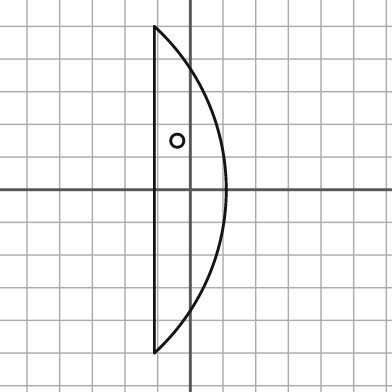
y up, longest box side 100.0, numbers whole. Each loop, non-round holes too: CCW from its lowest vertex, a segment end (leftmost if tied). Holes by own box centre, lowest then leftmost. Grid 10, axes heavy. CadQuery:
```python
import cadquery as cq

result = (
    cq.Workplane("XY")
    .moveTo(-11.0, -50.0)
    .threePointArc((11.0, 0.0), (-11.0, 50.0))
    .close()
    .moveTo(-4.0, 15.0)
    .circle(2.0)
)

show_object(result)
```